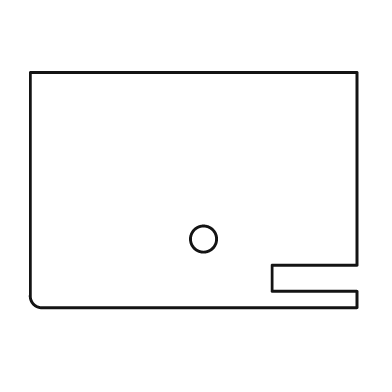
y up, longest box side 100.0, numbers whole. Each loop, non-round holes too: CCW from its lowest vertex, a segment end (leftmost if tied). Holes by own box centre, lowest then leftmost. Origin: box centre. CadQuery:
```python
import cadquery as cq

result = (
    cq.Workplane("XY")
    .moveTo(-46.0, -36.0)
    .lineTo(50.0, -36.0)
    .lineTo(50.0, -31.0)
    .lineTo(24.0, -31.0)
    .lineTo(24.0, -23.0)
    .lineTo(50.0, -23.0)
    .lineTo(50.0, 36.0)
    .lineTo(-50.0, 36.0)
    .lineTo(-50.0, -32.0)
    .threePointArc((-49.0, -35.0), (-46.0, -36.0))
    .close()
    .moveTo(3.0, -15.0)
    .circle(4.0)
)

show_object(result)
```